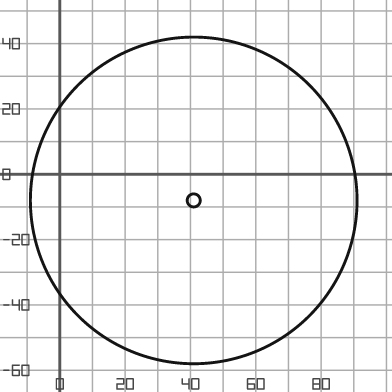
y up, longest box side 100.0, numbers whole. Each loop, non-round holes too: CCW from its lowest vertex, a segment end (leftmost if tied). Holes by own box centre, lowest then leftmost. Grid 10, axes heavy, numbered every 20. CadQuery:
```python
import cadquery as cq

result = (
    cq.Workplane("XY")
    .moveTo(41.0, -8.0)
    .circle(50.0)
    .moveTo(41.0, -8.0)
    .circle(2.0)
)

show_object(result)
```